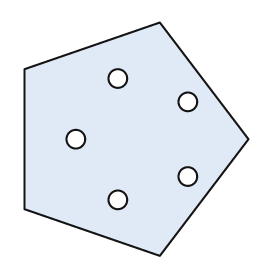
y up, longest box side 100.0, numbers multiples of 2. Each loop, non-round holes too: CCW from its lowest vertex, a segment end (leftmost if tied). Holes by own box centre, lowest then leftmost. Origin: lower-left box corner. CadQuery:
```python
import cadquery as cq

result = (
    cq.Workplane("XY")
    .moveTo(58.0, 0.0)
    .lineTo(96.0, 50.0)
    .lineTo(58.0, 100.0)
    .lineTo(0.0, 80.0)
    .lineTo(0.0, 20.0)
    .close()
    .moveTo(40.0, 24.0)
    .circle(4.0)
    .moveTo(70.0, 34.0)
    .circle(4.0)
    .moveTo(22.0, 50.0)
    .circle(4.0)
    .moveTo(70.0, 66.0)
    .circle(4.0)
    .moveTo(40.0, 76.0)
    .circle(4.0)
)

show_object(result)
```